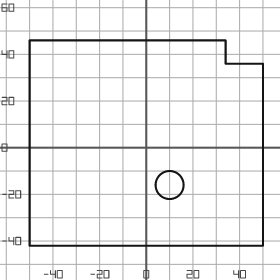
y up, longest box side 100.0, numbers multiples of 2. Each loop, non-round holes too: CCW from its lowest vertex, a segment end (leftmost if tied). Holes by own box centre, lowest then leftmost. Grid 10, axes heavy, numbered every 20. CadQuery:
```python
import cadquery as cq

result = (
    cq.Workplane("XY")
    .moveTo(-50.0, -42.0)
    .lineTo(50.0, -42.0)
    .lineTo(50.0, 36.0)
    .lineTo(34.0, 36.0)
    .lineTo(34.0, 46.0)
    .lineTo(-50.0, 46.0)
    .close()
    .moveTo(10.0, -16.0)
    .circle(6.0)
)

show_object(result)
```